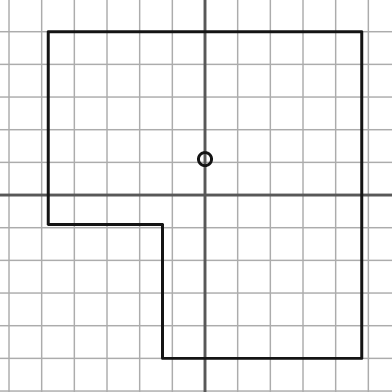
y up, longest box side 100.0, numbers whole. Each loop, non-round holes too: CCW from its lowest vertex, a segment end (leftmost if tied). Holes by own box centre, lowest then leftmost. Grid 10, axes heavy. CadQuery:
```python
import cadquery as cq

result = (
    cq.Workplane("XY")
    .moveTo(-13.0, -50.0)
    .lineTo(48.0, -50.0)
    .lineTo(48.0, 50.0)
    .lineTo(-48.0, 50.0)
    .lineTo(-48.0, -9.0)
    .lineTo(-13.0, -9.0)
    .close()
    .moveTo(0.0, 11.0)
    .circle(2.0)
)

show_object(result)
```